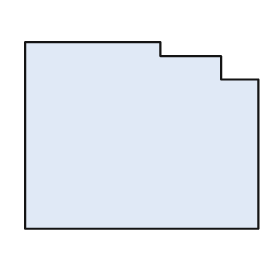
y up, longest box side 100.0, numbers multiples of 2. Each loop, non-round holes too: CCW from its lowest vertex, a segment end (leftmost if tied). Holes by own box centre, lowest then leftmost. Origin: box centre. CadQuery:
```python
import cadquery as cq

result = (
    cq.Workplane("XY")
    .moveTo(-50.0, -40.0)
    .lineTo(50.0, -40.0)
    .lineTo(50.0, 24.0)
    .lineTo(34.0, 24.0)
    .lineTo(34.0, 34.0)
    .lineTo(8.0, 34.0)
    .lineTo(8.0, 40.0)
    .lineTo(-50.0, 40.0)
    .close()
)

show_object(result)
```